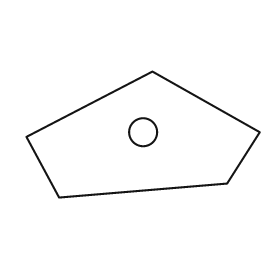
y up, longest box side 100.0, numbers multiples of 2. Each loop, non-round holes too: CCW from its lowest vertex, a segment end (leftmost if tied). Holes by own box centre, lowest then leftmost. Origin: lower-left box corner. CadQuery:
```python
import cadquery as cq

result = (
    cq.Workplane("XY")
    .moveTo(14.0, 0.0)
    .lineTo(86.0, 6.0)
    .lineTo(100.0, 28.0)
    .lineTo(54.0, 54.0)
    .lineTo(0.0, 26.0)
    .close()
    .moveTo(50.0, 28.0)
    .circle(6.0)
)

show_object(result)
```